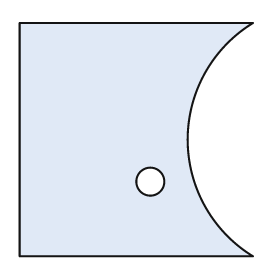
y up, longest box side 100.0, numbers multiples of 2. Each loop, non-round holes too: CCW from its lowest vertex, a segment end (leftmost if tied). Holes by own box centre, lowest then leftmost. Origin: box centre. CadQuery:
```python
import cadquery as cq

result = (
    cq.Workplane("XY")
    .moveTo(-50.0, -50.0)
    .lineTo(50.0, -50.0)
    .threePointArc((22.0, 0.0), (50.0, 50.0))
    .lineTo(-50.0, 50.0)
    .close()
    .moveTo(6.0, -18.0)
    .circle(6.0)
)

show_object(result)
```